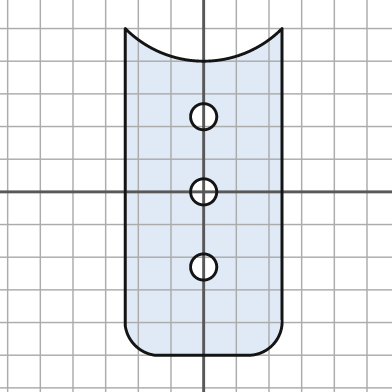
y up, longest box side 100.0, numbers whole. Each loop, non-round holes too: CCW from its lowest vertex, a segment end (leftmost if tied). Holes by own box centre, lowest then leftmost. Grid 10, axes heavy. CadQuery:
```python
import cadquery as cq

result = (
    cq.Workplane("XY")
    .moveTo(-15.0, -50.0)
    .lineTo(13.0, -50.0)
    .threePointArc((21.0, -47.0), (24.0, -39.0))
    .lineTo(24.0, 50.0)
    .threePointArc((0.0, 40.0), (-24.0, 50.0))
    .lineTo(-24.0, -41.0)
    .threePointArc((-21.0, -47.0), (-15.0, -50.0))
    .close()
    .moveTo(0.0, -23.0)
    .circle(4.0)
    .moveTo(0.0, 0.0)
    .circle(4.0)
    .moveTo(0.0, 23.0)
    .circle(4.0)
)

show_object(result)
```